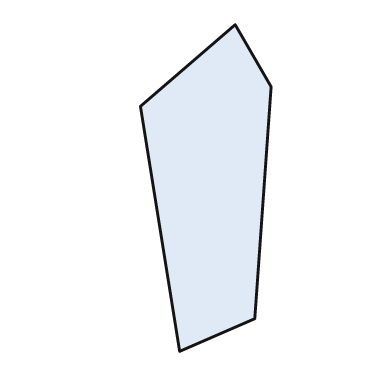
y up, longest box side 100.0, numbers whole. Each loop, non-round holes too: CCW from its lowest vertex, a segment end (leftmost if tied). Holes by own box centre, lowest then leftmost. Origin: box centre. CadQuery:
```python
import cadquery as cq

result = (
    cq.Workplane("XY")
    .moveTo(-8.0, -50.0)
    .lineTo(15.0, -40.0)
    .lineTo(20.0, 31.0)
    .lineTo(9.0, 50.0)
    .lineTo(-20.0, 25.0)
    .close()
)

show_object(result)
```